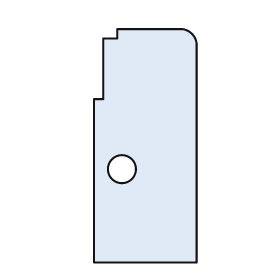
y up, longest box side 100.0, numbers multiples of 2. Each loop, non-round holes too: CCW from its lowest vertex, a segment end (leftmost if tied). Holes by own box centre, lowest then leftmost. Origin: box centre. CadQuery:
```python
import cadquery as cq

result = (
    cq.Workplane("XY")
    .moveTo(-22.0, -50.0)
    .lineTo(22.0, -50.0)
    .lineTo(22.0, 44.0)
    .threePointArc((20.0, 48.0), (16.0, 50.0))
    .lineTo(-12.0, 50.0)
    .lineTo(-12.0, 46.0)
    .lineTo(-18.0, 46.0)
    .lineTo(-18.0, 20.0)
    .lineTo(-22.0, 20.0)
    .close()
    .moveTo(-10.0, -10.0)
    .circle(6.0)
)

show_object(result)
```